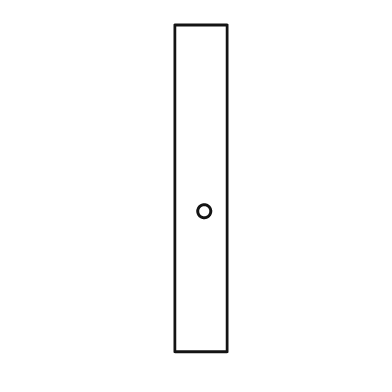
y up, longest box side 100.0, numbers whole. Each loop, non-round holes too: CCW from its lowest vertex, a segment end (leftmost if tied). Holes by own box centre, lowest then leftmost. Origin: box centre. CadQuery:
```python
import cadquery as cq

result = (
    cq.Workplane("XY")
    .moveTo(-8.0, -50.0)
    .lineTo(8.0, -50.0)
    .lineTo(8.0, 50.0)
    .lineTo(-8.0, 50.0)
    .close()
    .moveTo(1.0, -7.0)
    .circle(2.0)
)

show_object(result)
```